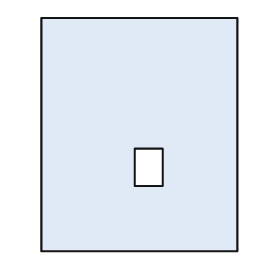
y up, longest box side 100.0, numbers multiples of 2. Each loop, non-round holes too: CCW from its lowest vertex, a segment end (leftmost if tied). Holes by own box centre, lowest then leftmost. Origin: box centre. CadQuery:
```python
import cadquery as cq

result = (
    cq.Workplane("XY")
    .moveTo(-42.0, -50.0)
    .lineTo(42.0, -50.0)
    .lineTo(42.0, 50.0)
    .lineTo(-42.0, 50.0)
    .close()
    .moveTo(-2.0, -22.0)
    .lineTo(10.0, -22.0)
    .lineTo(10.0, -6.0)
    .lineTo(-2.0, -6.0)
    .close()
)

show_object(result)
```